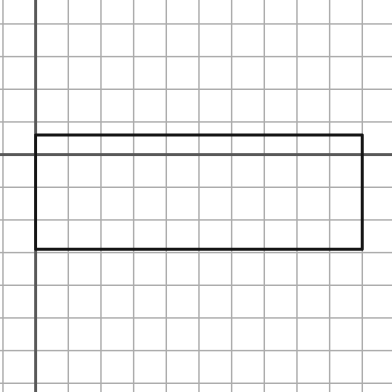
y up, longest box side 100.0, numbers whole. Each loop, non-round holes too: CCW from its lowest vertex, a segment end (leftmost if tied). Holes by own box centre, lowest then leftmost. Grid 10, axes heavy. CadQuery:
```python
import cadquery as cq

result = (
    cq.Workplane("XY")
    .moveTo(0.0, -29.0)
    .lineTo(100.0, -29.0)
    .lineTo(100.0, 6.0)
    .lineTo(0.0, 6.0)
    .close()
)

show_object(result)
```